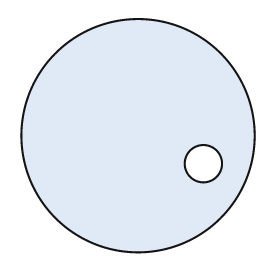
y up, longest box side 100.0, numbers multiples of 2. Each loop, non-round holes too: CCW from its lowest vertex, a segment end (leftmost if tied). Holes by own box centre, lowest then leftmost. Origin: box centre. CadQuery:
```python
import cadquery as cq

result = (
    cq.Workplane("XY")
    .moveTo(0.0, 0.0)
    .circle(50.0)
    .moveTo(28.0, -12.0)
    .circle(8.0)
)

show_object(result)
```